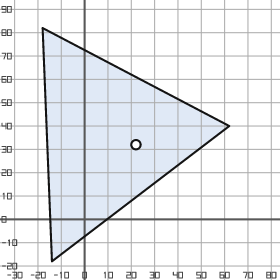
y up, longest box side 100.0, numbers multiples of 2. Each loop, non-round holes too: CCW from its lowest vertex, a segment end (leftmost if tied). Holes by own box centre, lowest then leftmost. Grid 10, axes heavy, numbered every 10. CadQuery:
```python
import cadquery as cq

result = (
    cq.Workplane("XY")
    .moveTo(-14.0, -18.0)
    .lineTo(62.0, 40.0)
    .lineTo(-18.0, 82.0)
    .close()
    .moveTo(22.0, 32.0)
    .circle(2.0)
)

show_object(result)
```